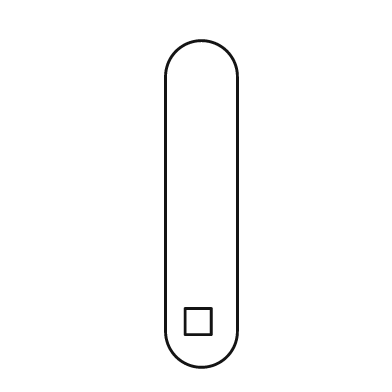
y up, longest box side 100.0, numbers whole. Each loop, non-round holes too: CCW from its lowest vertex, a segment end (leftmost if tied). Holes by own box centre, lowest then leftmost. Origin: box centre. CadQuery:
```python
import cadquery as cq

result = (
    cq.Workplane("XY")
    .moveTo(-11.0, -39.0)
    .threePointArc((0.0, -50.0), (11.0, -39.0))
    .lineTo(11.0, 39.0)
    .threePointArc((0.0, 50.0), (-11.0, 39.0))
    .close()
    .moveTo(-5.0, -40.0)
    .lineTo(3.0, -40.0)
    .lineTo(3.0, -32.0)
    .lineTo(-5.0, -32.0)
    .close()
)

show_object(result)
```